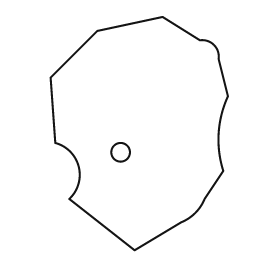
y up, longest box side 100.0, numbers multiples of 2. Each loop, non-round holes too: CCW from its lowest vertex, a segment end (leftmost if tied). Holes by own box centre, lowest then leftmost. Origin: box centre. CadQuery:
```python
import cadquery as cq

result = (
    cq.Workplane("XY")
    .moveTo(-2.0, -50.0)
    .lineTo(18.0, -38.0)
    .threePointArc((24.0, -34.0), (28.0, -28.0))
    .lineTo(36.0, -16.0)
    .threePointArc((34.0, 0.0), (38.0, 16.0))
    .lineTo(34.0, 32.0)
    .threePointArc((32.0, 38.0), (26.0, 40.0))
    .lineTo(10.0, 50.0)
    .lineTo(-18.0, 44.0)
    .lineTo(-38.0, 24.0)
    .lineTo(-36.0, -4.0)
    .threePointArc((-26.0, -14.0), (-30.0, -28.0))
    .close()
    .moveTo(-8.0, -8.0)
    .circle(4.0)
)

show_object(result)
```